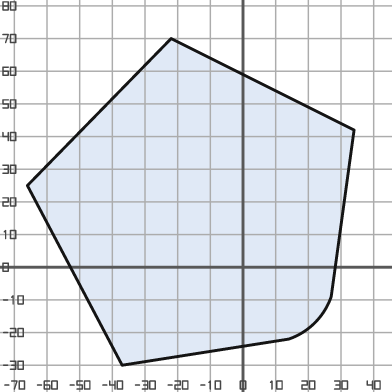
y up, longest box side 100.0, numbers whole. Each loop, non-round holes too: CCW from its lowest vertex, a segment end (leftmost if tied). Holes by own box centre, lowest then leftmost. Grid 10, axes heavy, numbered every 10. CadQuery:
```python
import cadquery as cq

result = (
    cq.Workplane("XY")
    .moveTo(-37.0, -30.0)
    .lineTo(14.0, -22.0)
    .threePointArc((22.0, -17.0), (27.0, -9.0))
    .lineTo(34.0, 42.0)
    .lineTo(-22.0, 70.0)
    .lineTo(-66.0, 25.0)
    .close()
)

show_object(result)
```